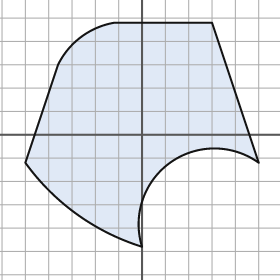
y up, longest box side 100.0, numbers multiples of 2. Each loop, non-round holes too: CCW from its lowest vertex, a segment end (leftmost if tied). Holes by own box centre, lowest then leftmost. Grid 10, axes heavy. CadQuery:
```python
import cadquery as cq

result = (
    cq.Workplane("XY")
    .moveTo(0.0, -48.0)
    .threePointArc((12.0, -12.0), (50.0, -12.0))
    .lineTo(30.0, 48.0)
    .lineTo(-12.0, 48.0)
    .threePointArc((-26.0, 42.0), (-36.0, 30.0))
    .lineTo(-50.0, -12.0)
    .threePointArc((-28.0, -34.0), (0.0, -48.0))
    .close()
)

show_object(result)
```